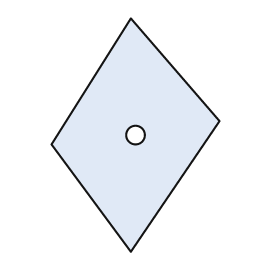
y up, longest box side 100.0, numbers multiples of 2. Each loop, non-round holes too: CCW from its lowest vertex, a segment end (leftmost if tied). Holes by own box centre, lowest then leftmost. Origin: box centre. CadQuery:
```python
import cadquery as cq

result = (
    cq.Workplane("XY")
    .moveTo(-2.0, -50.0)
    .lineTo(36.0, 6.0)
    .lineTo(-2.0, 50.0)
    .lineTo(-36.0, -4.0)
    .close()
    .moveTo(0.0, 0.0)
    .circle(4.0)
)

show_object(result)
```